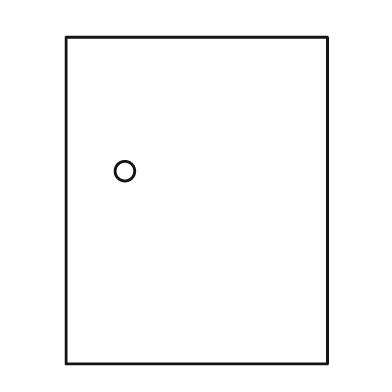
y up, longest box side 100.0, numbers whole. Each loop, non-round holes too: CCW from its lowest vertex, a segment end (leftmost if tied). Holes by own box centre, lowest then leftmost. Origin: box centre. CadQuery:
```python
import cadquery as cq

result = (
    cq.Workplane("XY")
    .moveTo(-40.0, -50.0)
    .lineTo(40.0, -50.0)
    .lineTo(40.0, 50.0)
    .lineTo(-40.0, 50.0)
    .close()
    .moveTo(-22.0, 9.0)
    .circle(3.0)
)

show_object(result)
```